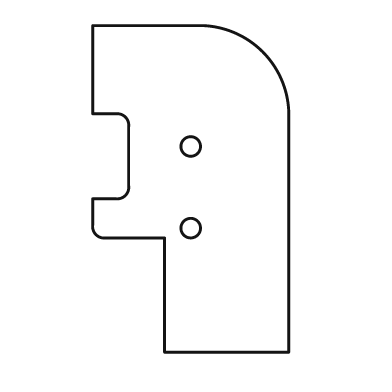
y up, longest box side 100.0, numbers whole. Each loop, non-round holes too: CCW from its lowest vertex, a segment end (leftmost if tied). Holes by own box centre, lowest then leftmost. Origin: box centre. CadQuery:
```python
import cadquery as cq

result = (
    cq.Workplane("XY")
    .moveTo(-8.0, -50.0)
    .lineTo(30.0, -50.0)
    .lineTo(30.0, 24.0)
    .threePointArc((22.0, 42.0), (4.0, 50.0))
    .lineTo(-30.0, 50.0)
    .lineTo(-30.0, 23.0)
    .lineTo(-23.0, 23.0)
    .threePointArc((-20.0, 22.0), (-19.0, 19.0))
    .lineTo(-19.0, 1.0)
    .threePointArc((-20.0, -2.0), (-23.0, -3.0))
    .lineTo(-30.0, -3.0)
    .lineTo(-30.0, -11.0)
    .threePointArc((-29.0, -14.0), (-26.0, -15.0))
    .lineTo(-8.0, -15.0)
    .close()
    .moveTo(0.0, -12.0)
    .circle(3.0)
    .moveTo(0.0, 13.0)
    .circle(3.0)
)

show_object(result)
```